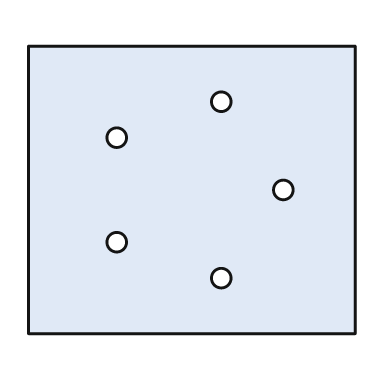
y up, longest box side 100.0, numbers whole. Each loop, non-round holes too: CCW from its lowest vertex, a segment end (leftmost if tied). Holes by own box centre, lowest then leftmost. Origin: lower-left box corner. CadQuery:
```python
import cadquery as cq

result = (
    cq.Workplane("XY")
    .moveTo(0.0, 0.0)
    .lineTo(100.0, 0.0)
    .lineTo(100.0, 88.0)
    .lineTo(0.0, 88.0)
    .close()
    .moveTo(59.0, 17.0)
    .circle(3.0)
    .moveTo(27.0, 28.0)
    .circle(3.0)
    .moveTo(78.0, 44.0)
    .circle(3.0)
    .moveTo(27.0, 60.0)
    .circle(3.0)
    .moveTo(59.0, 71.0)
    .circle(3.0)
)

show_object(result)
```